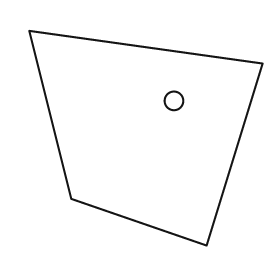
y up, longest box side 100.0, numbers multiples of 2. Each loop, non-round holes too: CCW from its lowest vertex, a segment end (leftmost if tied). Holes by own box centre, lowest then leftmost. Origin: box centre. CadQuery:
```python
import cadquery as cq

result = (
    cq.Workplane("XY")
    .moveTo(26.0, -46.0)
    .lineTo(50.0, 32.0)
    .lineTo(-50.0, 46.0)
    .lineTo(-32.0, -26.0)
    .close()
    .moveTo(12.0, 16.0)
    .circle(4.0)
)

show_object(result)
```